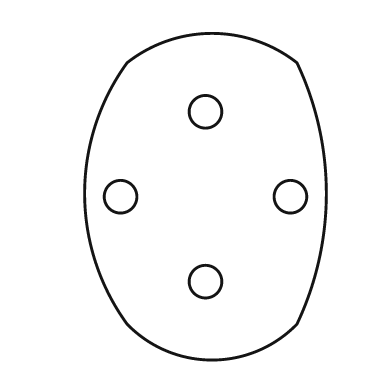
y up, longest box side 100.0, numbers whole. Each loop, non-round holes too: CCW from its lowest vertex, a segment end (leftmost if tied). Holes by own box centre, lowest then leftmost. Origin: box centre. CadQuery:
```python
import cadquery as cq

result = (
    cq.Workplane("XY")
    .moveTo(-24.0, -39.0)
    .threePointArc((2.0, -50.0), (28.0, -39.0))
    .threePointArc((37.0, 1.0), (28.0, 41.0))
    .threePointArc((2.0, 50.0), (-24.0, 41.0))
    .threePointArc((-37.0, 1.0), (-24.0, -39.0))
    .close()
    .moveTo(0.0, -26.0)
    .circle(5.0)
    .moveTo(-26.0, 0.0)
    .circle(5.0)
    .moveTo(26.0, 0.0)
    .circle(5.0)
    .moveTo(0.0, 26.0)
    .circle(5.0)
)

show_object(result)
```